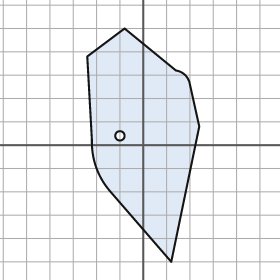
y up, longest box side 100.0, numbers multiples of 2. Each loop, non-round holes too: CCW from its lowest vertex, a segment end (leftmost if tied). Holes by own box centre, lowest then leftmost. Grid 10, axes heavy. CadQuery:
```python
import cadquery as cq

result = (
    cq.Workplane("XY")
    .moveTo(12.0, -50.0)
    .lineTo(24.0, 8.0)
    .lineTo(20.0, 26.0)
    .threePointArc((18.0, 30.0), (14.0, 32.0))
    .lineTo(-8.0, 50.0)
    .lineTo(-24.0, 38.0)
    .lineTo(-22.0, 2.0)
    .threePointArc((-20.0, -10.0), (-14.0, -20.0))
    .close()
    .moveTo(-10.0, 4.0)
    .circle(2.0)
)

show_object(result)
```